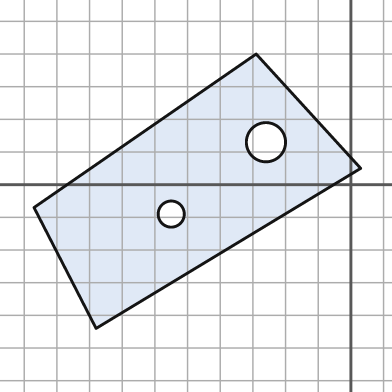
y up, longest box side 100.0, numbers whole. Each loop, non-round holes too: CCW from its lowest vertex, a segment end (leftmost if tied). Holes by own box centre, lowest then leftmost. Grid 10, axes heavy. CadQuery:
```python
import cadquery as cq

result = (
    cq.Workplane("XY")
    .moveTo(-78.0, -44.0)
    .lineTo(3.0, 5.0)
    .lineTo(-29.0, 40.0)
    .lineTo(-97.0, -7.0)
    .close()
    .moveTo(-55.0, -9.0)
    .circle(4.0)
    .moveTo(-26.0, 13.0)
    .circle(6.0)
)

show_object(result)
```